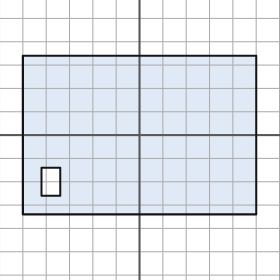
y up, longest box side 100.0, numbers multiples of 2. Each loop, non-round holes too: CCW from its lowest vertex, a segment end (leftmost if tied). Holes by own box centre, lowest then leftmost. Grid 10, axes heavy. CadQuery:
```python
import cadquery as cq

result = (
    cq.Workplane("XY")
    .moveTo(-50.0, -34.0)
    .lineTo(50.0, -34.0)
    .lineTo(50.0, 34.0)
    .lineTo(-50.0, 34.0)
    .close()
    .moveTo(-42.0, -26.0)
    .lineTo(-34.0, -26.0)
    .lineTo(-34.0, -14.0)
    .lineTo(-42.0, -14.0)
    .close()
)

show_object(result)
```